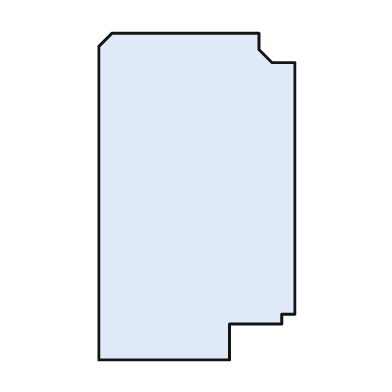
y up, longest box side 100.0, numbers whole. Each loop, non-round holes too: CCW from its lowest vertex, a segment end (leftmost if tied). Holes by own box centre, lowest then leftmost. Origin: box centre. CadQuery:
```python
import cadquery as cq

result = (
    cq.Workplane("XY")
    .moveTo(-30.0, -50.0)
    .lineTo(10.0, -50.0)
    .lineTo(10.0, -39.0)
    .lineTo(26.0, -39.0)
    .lineTo(26.0, -36.0)
    .lineTo(30.0, -36.0)
    .lineTo(30.0, 41.0)
    .lineTo(23.0, 41.0)
    .lineTo(19.0, 45.0)
    .lineTo(19.0, 50.0)
    .lineTo(-26.0, 50.0)
    .lineTo(-30.0, 46.0)
    .close()
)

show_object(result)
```